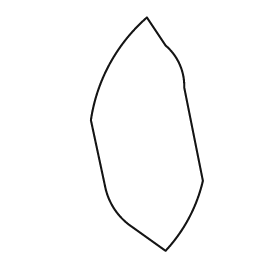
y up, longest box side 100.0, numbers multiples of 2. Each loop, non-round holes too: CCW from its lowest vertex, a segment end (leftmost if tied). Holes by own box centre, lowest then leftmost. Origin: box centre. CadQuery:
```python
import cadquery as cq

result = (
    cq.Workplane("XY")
    .moveTo(8.0, -50.0)
    .threePointArc((18.0, -36.0), (24.0, -20.0))
    .lineTo(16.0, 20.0)
    .threePointArc((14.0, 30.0), (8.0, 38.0))
    .lineTo(0.0, 50.0)
    .threePointArc((-16.0, 30.0), (-24.0, 6.0))
    .lineTo(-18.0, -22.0)
    .threePointArc((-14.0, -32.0), (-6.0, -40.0))
    .close()
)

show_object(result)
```